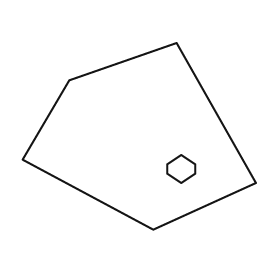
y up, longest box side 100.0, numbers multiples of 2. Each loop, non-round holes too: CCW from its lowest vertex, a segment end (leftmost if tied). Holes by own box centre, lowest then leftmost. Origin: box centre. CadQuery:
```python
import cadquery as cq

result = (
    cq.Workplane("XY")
    .moveTo(6.0, -40.0)
    .lineTo(50.0, -20.0)
    .lineTo(16.0, 40.0)
    .lineTo(-30.0, 24.0)
    .lineTo(-50.0, -10.0)
    .close()
    .moveTo(18.0, -20.0)
    .lineTo(24.0, -16.0)
    .lineTo(24.0, -12.0)
    .lineTo(18.0, -8.0)
    .lineTo(12.0, -12.0)
    .lineTo(12.0, -16.0)
    .close()
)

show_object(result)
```